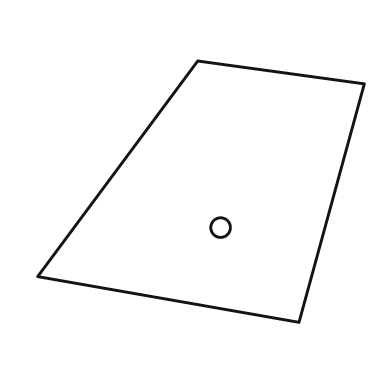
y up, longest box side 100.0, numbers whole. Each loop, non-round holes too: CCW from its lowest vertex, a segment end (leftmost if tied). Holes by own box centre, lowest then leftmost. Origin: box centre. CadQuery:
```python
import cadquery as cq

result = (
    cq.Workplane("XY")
    .moveTo(30.0, -40.0)
    .lineTo(50.0, 33.0)
    .lineTo(-1.0, 40.0)
    .lineTo(-50.0, -26.0)
    .close()
    .moveTo(6.0, -11.0)
    .circle(3.0)
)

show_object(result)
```